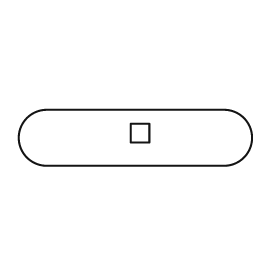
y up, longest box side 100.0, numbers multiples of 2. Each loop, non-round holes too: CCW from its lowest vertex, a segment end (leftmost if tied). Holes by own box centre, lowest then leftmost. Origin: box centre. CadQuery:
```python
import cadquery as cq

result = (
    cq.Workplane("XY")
    .moveTo(-38.0, -12.0)
    .lineTo(38.0, -12.0)
    .threePointArc((50.0, 0.0), (38.0, 12.0))
    .lineTo(-38.0, 12.0)
    .threePointArc((-50.0, 0.0), (-38.0, -12.0))
    .close()
    .moveTo(-2.0, -2.0)
    .lineTo(6.0, -2.0)
    .lineTo(6.0, 6.0)
    .lineTo(-2.0, 6.0)
    .close()
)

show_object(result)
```